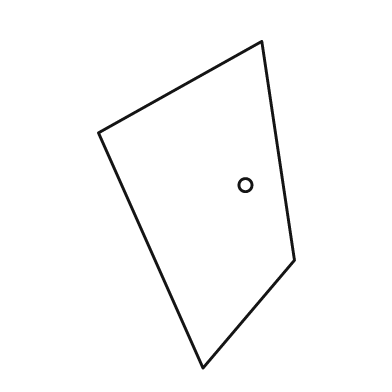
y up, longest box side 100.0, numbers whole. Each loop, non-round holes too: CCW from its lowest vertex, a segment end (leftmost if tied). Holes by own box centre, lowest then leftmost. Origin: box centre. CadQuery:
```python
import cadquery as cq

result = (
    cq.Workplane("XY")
    .moveTo(2.0, -50.0)
    .lineTo(30.0, -17.0)
    .lineTo(20.0, 50.0)
    .lineTo(-30.0, 22.0)
    .close()
    .moveTo(15.0, 6.0)
    .circle(2.0)
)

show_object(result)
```